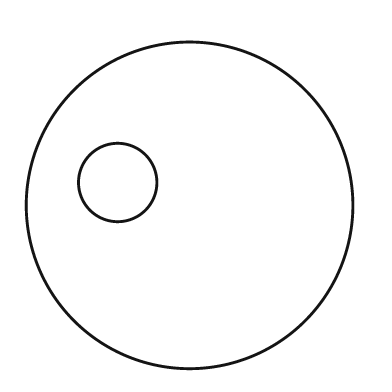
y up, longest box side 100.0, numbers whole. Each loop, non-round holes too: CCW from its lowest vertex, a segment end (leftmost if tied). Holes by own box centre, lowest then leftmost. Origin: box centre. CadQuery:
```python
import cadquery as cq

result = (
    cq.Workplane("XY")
    .moveTo(0.0, 0.0)
    .circle(50.0)
    .moveTo(-22.0, 7.0)
    .circle(12.0)
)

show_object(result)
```